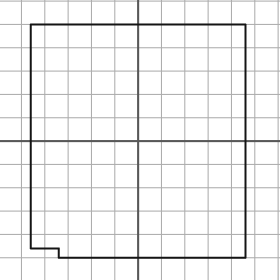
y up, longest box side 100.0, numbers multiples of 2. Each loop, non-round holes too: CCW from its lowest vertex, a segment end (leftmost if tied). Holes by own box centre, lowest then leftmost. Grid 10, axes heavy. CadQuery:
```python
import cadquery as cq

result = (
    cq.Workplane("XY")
    .moveTo(-34.0, -50.0)
    .lineTo(46.0, -50.0)
    .lineTo(46.0, 50.0)
    .lineTo(-46.0, 50.0)
    .lineTo(-46.0, -46.0)
    .lineTo(-34.0, -46.0)
    .close()
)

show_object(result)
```